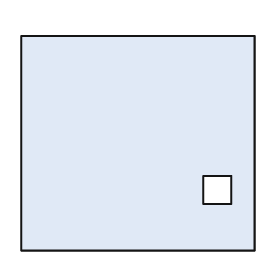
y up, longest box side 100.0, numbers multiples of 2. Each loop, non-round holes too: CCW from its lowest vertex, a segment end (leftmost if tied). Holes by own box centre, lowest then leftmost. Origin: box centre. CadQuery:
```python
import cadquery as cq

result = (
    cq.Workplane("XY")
    .moveTo(-50.0, -46.0)
    .lineTo(50.0, -46.0)
    .lineTo(50.0, 46.0)
    .lineTo(-50.0, 46.0)
    .close()
    .moveTo(28.0, -26.0)
    .lineTo(40.0, -26.0)
    .lineTo(40.0, -14.0)
    .lineTo(28.0, -14.0)
    .close()
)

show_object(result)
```